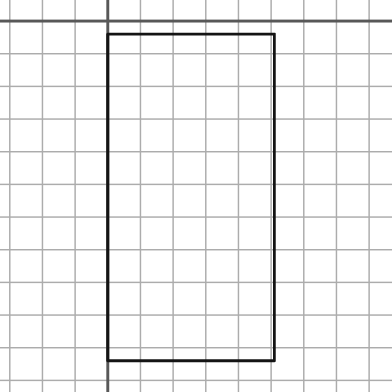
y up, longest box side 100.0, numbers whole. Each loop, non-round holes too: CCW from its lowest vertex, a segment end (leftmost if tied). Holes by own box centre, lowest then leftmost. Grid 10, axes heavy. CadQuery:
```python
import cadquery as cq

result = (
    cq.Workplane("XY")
    .moveTo(0.0, -104.0)
    .lineTo(51.0, -104.0)
    .lineTo(51.0, -4.0)
    .lineTo(0.0, -4.0)
    .close()
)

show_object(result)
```